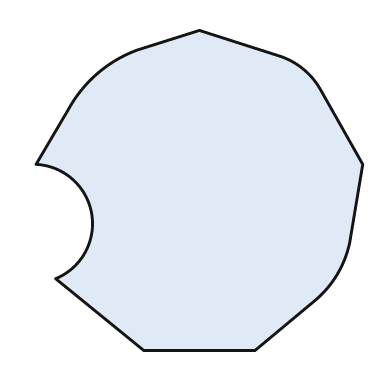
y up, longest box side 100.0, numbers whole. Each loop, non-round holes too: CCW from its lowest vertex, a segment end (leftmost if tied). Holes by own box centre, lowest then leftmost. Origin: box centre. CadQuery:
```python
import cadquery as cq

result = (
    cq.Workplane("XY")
    .moveTo(-17.0, -49.0)
    .lineTo(17.0, -49.0)
    .lineTo(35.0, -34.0)
    .threePointArc((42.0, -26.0), (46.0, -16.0))
    .lineTo(50.0, 8.0)
    .lineTo(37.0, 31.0)
    .threePointArc((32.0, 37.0), (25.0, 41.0))
    .lineTo(0.0, 49.0)
    .lineTo(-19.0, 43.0)
    .threePointArc((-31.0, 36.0), (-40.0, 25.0))
    .lineTo(-50.0, 8.0)
    .threePointArc((-33.0, -7.0), (-44.0, -27.0))
    .close()
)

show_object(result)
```